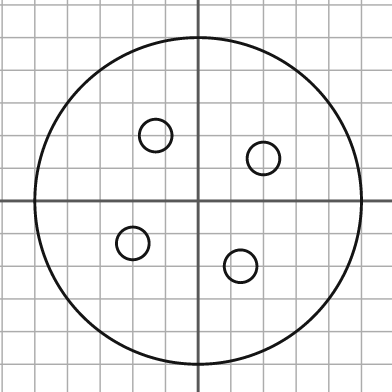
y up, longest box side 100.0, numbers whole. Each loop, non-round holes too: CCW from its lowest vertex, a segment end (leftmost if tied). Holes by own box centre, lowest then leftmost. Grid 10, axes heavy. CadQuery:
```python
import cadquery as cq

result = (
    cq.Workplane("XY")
    .moveTo(0.0, 0.0)
    .circle(50.0)
    .moveTo(13.0, -20.0)
    .circle(5.0)
    .moveTo(-20.0, -13.0)
    .circle(5.0)
    .moveTo(20.0, 13.0)
    .circle(5.0)
    .moveTo(-13.0, 20.0)
    .circle(5.0)
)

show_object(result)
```